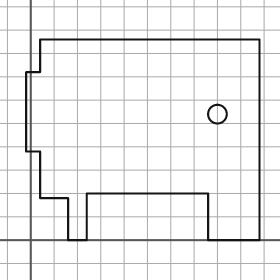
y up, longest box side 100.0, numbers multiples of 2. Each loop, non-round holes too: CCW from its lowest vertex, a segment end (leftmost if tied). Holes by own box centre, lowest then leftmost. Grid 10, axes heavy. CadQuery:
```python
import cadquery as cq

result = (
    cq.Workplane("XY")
    .moveTo(16.0, 0.0)
    .lineTo(24.0, 0.0)
    .lineTo(24.0, 20.0)
    .lineTo(76.0, 20.0)
    .lineTo(76.0, 0.0)
    .lineTo(98.0, 0.0)
    .lineTo(98.0, 86.0)
    .lineTo(4.0, 86.0)
    .lineTo(4.0, 72.0)
    .lineTo(-2.0, 72.0)
    .lineTo(-2.0, 38.0)
    .lineTo(4.0, 38.0)
    .lineTo(4.0, 18.0)
    .lineTo(16.0, 18.0)
    .close()
    .moveTo(80.0, 54.0)
    .circle(4.0)
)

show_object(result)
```